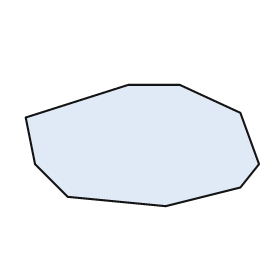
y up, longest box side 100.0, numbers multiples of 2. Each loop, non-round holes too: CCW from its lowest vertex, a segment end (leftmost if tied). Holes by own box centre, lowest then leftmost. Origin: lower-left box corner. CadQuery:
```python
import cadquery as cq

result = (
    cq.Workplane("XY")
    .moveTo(60.0, 0.0)
    .lineTo(92.0, 8.0)
    .lineTo(100.0, 18.0)
    .lineTo(92.0, 40.0)
    .lineTo(66.0, 52.0)
    .lineTo(44.0, 52.0)
    .lineTo(0.0, 38.0)
    .lineTo(4.0, 18.0)
    .lineTo(18.0, 4.0)
    .close()
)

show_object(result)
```